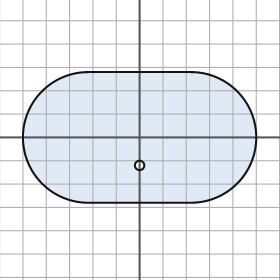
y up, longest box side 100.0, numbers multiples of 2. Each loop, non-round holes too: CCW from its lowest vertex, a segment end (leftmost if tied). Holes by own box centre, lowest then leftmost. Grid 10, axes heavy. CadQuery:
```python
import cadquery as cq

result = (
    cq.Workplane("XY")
    .moveTo(-22.0, -28.0)
    .lineTo(22.0, -28.0)
    .threePointArc((50.0, 0.0), (22.0, 28.0))
    .lineTo(-22.0, 28.0)
    .threePointArc((-50.0, 0.0), (-22.0, -28.0))
    .close()
    .moveTo(0.0, -12.0)
    .circle(2.0)
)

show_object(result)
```